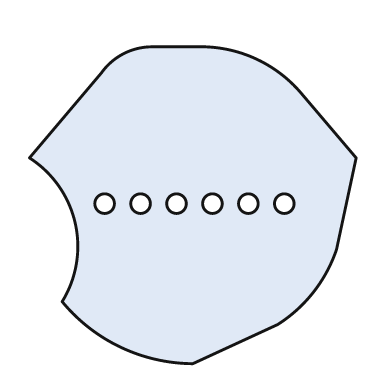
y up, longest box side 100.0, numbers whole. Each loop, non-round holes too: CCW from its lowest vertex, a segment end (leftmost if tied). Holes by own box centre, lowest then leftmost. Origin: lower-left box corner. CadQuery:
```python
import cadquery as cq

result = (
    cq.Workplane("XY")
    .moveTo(50.0, 0.0)
    .lineTo(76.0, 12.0)
    .threePointArc((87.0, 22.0), (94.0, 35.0))
    .lineTo(100.0, 63.0)
    .lineTo(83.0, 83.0)
    .threePointArc((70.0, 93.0), (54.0, 97.0))
    .lineTo(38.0, 97.0)
    .threePointArc((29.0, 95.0), (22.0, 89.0))
    .lineTo(0.0, 63.0)
    .threePointArc((14.0, 43.0), (10.0, 19.0))
    .threePointArc((28.0, 5.0), (50.0, 0.0))
    .close()
    .moveTo(23.0, 49.0)
    .circle(3.0)
    .moveTo(34.0, 49.0)
    .circle(3.0)
    .moveTo(45.0, 49.0)
    .circle(3.0)
    .moveTo(56.0, 49.0)
    .circle(3.0)
    .moveTo(67.0, 49.0)
    .circle(3.0)
    .moveTo(78.0, 49.0)
    .circle(3.0)
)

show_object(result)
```